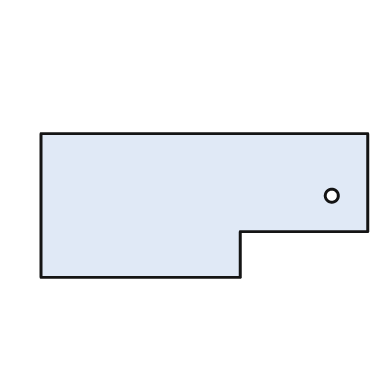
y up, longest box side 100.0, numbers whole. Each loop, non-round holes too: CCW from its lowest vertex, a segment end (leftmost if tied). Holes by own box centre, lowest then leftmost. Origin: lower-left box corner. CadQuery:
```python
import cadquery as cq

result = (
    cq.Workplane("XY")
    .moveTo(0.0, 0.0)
    .lineTo(61.0, 0.0)
    .lineTo(61.0, 14.0)
    .lineTo(100.0, 14.0)
    .lineTo(100.0, 44.0)
    .lineTo(0.0, 44.0)
    .close()
    .moveTo(89.0, 25.0)
    .circle(2.0)
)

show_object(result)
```